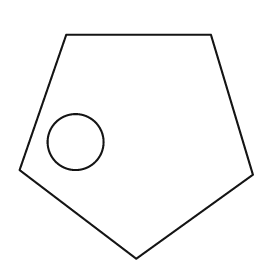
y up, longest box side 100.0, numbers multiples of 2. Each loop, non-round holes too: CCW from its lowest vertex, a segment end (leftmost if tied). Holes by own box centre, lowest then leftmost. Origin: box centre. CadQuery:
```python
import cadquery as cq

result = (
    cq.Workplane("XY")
    .moveTo(0.0, -48.0)
    .lineTo(50.0, -12.0)
    .lineTo(32.0, 48.0)
    .lineTo(-30.0, 48.0)
    .lineTo(-50.0, -10.0)
    .close()
    .moveTo(-26.0, 2.0)
    .circle(12.0)
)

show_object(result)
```